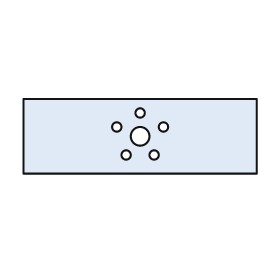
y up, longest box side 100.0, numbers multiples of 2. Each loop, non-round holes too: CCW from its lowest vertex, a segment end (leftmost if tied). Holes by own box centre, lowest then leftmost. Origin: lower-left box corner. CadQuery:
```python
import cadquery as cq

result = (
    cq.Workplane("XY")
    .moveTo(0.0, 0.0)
    .lineTo(100.0, 0.0)
    .lineTo(100.0, 32.0)
    .lineTo(0.0, 32.0)
    .close()
    .moveTo(44.0, 8.0)
    .circle(2.0)
    .moveTo(56.0, 8.0)
    .circle(2.0)
    .moveTo(50.0, 16.0)
    .circle(4.0)
    .moveTo(40.0, 20.0)
    .circle(2.0)
    .moveTo(60.0, 20.0)
    .circle(2.0)
    .moveTo(50.0, 26.0)
    .circle(2.0)
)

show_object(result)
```